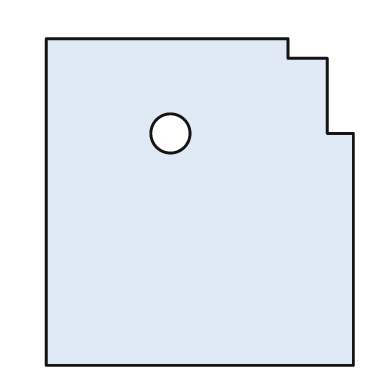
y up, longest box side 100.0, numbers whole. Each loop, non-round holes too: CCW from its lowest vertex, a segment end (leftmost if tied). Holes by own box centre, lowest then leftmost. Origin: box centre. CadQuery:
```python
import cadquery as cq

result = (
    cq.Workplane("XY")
    .moveTo(-47.0, -50.0)
    .lineTo(47.0, -50.0)
    .lineTo(47.0, 21.0)
    .lineTo(39.0, 21.0)
    .lineTo(39.0, 44.0)
    .lineTo(27.0, 44.0)
    .lineTo(27.0, 50.0)
    .lineTo(-47.0, 50.0)
    .close()
    .moveTo(-9.0, 21.0)
    .circle(6.0)
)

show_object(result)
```